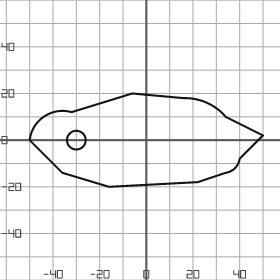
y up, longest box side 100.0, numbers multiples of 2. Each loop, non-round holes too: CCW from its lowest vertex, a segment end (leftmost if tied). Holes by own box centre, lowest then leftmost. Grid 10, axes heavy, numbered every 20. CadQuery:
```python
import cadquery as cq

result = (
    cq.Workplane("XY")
    .moveTo(-16.0, -20.0)
    .lineTo(22.0, -18.0)
    .lineTo(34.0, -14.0)
    .threePointArc((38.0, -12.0), (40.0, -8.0))
    .lineTo(50.0, 2.0)
    .lineTo(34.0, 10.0)
    .threePointArc((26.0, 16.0), (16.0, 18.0))
    .lineTo(-6.0, 20.0)
    .lineTo(-32.0, 12.0)
    .threePointArc((-44.0, 10.0), (-50.0, 0.0))
    .lineTo(-36.0, -14.0)
    .close()
    .moveTo(-30.0, 0.0)
    .circle(4.0)
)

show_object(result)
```